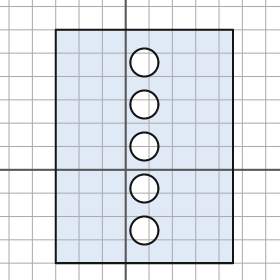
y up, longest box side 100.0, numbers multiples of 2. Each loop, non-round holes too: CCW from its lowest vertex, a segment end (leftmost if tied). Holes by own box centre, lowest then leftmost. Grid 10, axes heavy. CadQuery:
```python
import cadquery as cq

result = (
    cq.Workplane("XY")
    .moveTo(-30.0, -40.0)
    .lineTo(46.0, -40.0)
    .lineTo(46.0, 60.0)
    .lineTo(-30.0, 60.0)
    .close()
    .moveTo(8.0, -26.0)
    .circle(6.0)
    .moveTo(8.0, -8.0)
    .circle(6.0)
    .moveTo(8.0, 10.0)
    .circle(6.0)
    .moveTo(8.0, 28.0)
    .circle(6.0)
    .moveTo(8.0, 46.0)
    .circle(6.0)
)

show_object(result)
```